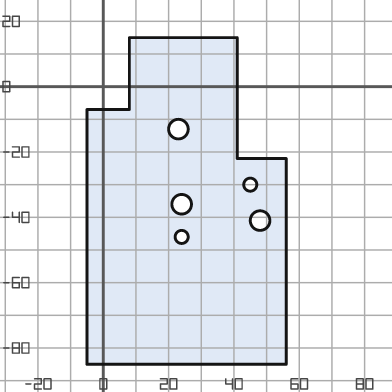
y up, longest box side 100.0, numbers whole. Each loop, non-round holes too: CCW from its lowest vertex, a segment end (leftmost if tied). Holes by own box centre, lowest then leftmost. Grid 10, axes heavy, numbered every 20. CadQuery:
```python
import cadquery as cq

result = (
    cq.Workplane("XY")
    .moveTo(-5.0, -85.0)
    .lineTo(56.0, -85.0)
    .lineTo(56.0, -22.0)
    .lineTo(41.0, -22.0)
    .lineTo(41.0, 15.0)
    .lineTo(8.0, 15.0)
    .lineTo(8.0, -7.0)
    .lineTo(-5.0, -7.0)
    .close()
    .moveTo(24.0, -46.0)
    .circle(2.0)
    .moveTo(48.0, -41.0)
    .circle(3.0)
    .moveTo(24.0, -36.0)
    .circle(3.0)
    .moveTo(45.0, -30.0)
    .circle(2.0)
    .moveTo(23.0, -13.0)
    .circle(3.0)
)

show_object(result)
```